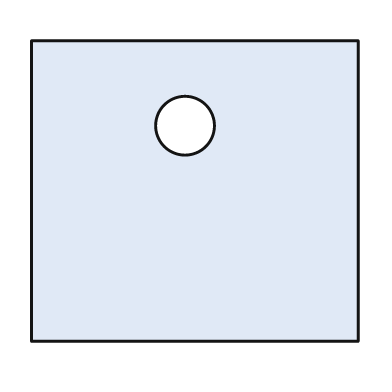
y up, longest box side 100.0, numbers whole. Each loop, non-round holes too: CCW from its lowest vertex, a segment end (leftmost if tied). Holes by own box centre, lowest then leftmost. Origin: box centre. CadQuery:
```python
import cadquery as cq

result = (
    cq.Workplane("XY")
    .moveTo(-50.0, -46.0)
    .lineTo(50.0, -46.0)
    .lineTo(50.0, 46.0)
    .lineTo(-50.0, 46.0)
    .close()
    .moveTo(-3.0, 20.0)
    .circle(9.0)
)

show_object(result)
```